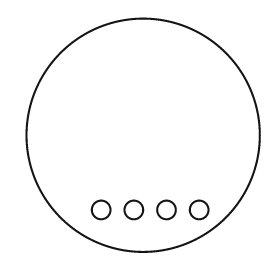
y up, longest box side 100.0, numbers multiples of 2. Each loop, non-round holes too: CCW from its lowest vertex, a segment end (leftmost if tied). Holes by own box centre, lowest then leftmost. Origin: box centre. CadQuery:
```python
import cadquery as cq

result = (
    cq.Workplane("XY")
    .moveTo(0.0, 0.0)
    .circle(50.0)
    .moveTo(-18.0, -32.0)
    .circle(4.0)
    .moveTo(-4.0, -32.0)
    .circle(4.0)
    .moveTo(10.0, -32.0)
    .circle(4.0)
    .moveTo(24.0, -32.0)
    .circle(4.0)
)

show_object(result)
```